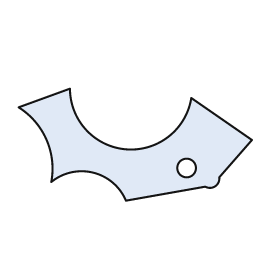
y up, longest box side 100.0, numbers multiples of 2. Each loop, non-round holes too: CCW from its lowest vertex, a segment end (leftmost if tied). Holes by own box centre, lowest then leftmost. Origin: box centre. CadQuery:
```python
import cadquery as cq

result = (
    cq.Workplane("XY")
    .moveTo(-4.0, -24.0)
    .lineTo(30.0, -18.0)
    .threePointArc((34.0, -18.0), (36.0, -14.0))
    .lineTo(50.0, 2.0)
    .lineTo(24.0, 20.0)
    .threePointArc((-4.0, -2.0), (-28.0, 24.0))
    .lineTo(-50.0, 16.0)
    .threePointArc((-38.0, 2.0), (-36.0, -16.0))
    .threePointArc((-18.0, -12.0), (-4.0, -24.0))
    .close()
    .moveTo(22.0, -10.0)
    .circle(4.0)
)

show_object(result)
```